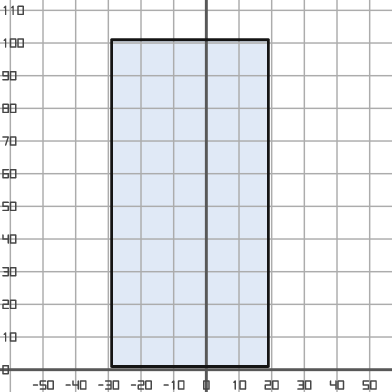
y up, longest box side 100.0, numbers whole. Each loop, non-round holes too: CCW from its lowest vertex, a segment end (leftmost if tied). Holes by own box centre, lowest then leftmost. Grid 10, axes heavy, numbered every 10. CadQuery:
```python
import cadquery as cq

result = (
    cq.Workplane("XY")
    .moveTo(-29.0, 1.0)
    .lineTo(19.0, 1.0)
    .lineTo(19.0, 101.0)
    .lineTo(-29.0, 101.0)
    .close()
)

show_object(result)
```